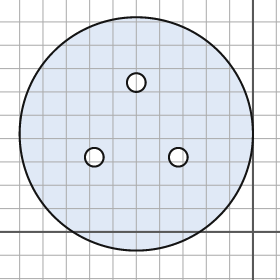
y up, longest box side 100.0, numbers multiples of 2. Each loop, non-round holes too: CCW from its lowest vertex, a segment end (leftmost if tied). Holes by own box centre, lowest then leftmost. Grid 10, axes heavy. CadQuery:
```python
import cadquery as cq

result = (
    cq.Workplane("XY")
    .moveTo(-50.0, 42.0)
    .circle(50.0)
    .moveTo(-68.0, 32.0)
    .circle(4.0)
    .moveTo(-32.0, 32.0)
    .circle(4.0)
    .moveTo(-50.0, 64.0)
    .circle(4.0)
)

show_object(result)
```